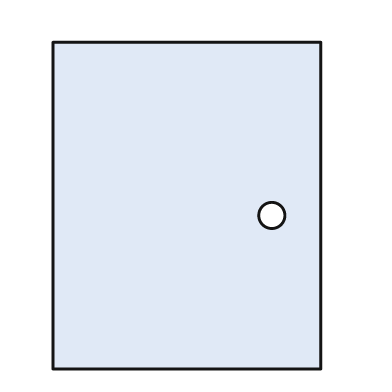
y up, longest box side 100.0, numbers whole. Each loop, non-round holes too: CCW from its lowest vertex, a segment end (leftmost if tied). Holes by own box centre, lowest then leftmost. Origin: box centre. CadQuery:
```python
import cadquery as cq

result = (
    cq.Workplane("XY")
    .moveTo(-41.0, -50.0)
    .lineTo(41.0, -50.0)
    .lineTo(41.0, 50.0)
    .lineTo(-41.0, 50.0)
    .close()
    .moveTo(26.0, -3.0)
    .circle(4.0)
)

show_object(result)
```